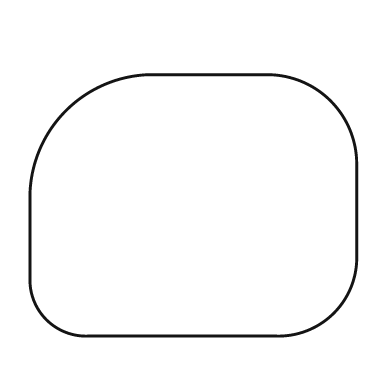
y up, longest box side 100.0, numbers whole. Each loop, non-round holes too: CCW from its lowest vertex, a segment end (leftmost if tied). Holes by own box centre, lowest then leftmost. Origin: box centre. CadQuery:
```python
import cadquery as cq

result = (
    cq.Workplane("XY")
    .moveTo(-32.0, -40.0)
    .lineTo(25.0, -40.0)
    .threePointArc((43.0, -33.0), (50.0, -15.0))
    .lineTo(50.0, 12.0)
    .threePointArc((42.0, 32.0), (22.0, 40.0))
    .lineTo(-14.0, 40.0)
    .threePointArc((-39.0, 29.0), (-50.0, 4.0))
    .lineTo(-50.0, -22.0)
    .threePointArc((-45.0, -35.0), (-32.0, -40.0))
    .close()
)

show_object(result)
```